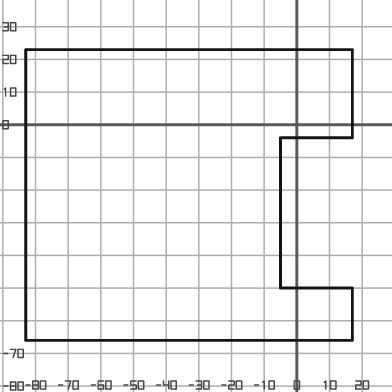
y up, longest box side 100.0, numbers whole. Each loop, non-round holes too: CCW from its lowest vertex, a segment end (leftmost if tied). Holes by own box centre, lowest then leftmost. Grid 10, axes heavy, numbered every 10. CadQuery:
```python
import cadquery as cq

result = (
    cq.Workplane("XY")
    .moveTo(-83.0, -66.0)
    .lineTo(17.0, -66.0)
    .lineTo(17.0, -50.0)
    .lineTo(-5.0, -50.0)
    .lineTo(-5.0, -4.0)
    .lineTo(17.0, -4.0)
    .lineTo(17.0, 23.0)
    .lineTo(-83.0, 23.0)
    .close()
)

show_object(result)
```